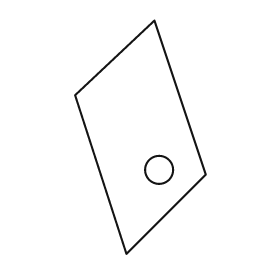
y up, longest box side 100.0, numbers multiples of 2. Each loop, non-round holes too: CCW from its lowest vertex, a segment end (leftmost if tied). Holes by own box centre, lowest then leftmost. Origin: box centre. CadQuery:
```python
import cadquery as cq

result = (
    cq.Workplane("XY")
    .moveTo(-6.0, -50.0)
    .lineTo(28.0, -16.0)
    .lineTo(6.0, 50.0)
    .lineTo(-28.0, 18.0)
    .close()
    .moveTo(8.0, -14.0)
    .circle(6.0)
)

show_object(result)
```